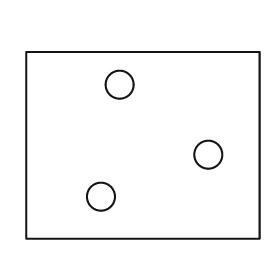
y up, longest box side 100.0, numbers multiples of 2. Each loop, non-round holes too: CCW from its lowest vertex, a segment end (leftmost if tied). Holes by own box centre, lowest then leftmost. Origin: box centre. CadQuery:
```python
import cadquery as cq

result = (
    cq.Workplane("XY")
    .moveTo(-50.0, -40.0)
    .lineTo(50.0, -40.0)
    .lineTo(50.0, 40.0)
    .lineTo(-50.0, 40.0)
    .close()
    .moveTo(-18.0, -22.0)
    .circle(6.0)
    .moveTo(28.0, -4.0)
    .circle(6.0)
    .moveTo(-10.0, 26.0)
    .circle(6.0)
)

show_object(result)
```